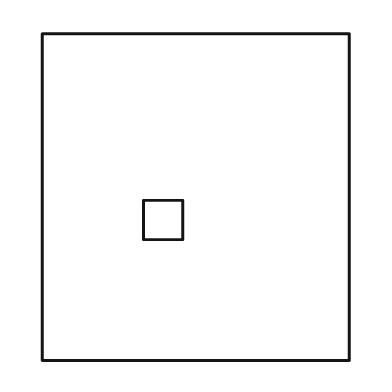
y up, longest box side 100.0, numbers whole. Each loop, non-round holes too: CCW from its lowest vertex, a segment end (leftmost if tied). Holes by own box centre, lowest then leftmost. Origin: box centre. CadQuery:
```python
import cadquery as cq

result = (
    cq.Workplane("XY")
    .moveTo(-47.0, -50.0)
    .lineTo(47.0, -50.0)
    .lineTo(47.0, 50.0)
    .lineTo(-47.0, 50.0)
    .close()
    .moveTo(-16.0, -13.0)
    .lineTo(-4.0, -13.0)
    .lineTo(-4.0, -1.0)
    .lineTo(-16.0, -1.0)
    .close()
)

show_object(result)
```